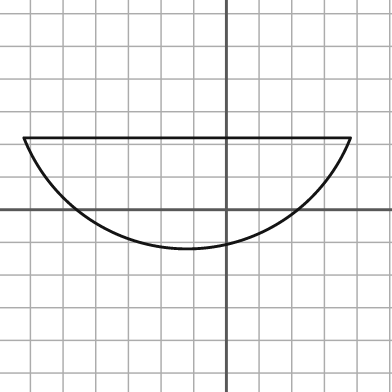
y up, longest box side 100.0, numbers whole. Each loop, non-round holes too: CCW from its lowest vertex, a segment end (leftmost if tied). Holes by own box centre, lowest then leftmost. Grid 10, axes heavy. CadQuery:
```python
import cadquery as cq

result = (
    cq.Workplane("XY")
    .moveTo(-62.0, 22.0)
    .threePointArc((-12.0, -12.0), (38.0, 22.0))
    .close()
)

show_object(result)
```